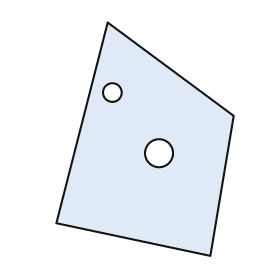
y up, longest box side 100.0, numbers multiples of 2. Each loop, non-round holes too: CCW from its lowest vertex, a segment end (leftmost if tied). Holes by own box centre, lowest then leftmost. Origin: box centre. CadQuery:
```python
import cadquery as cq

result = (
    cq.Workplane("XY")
    .moveTo(28.0, -50.0)
    .lineTo(38.0, 10.0)
    .lineTo(-16.0, 50.0)
    .lineTo(-38.0, -36.0)
    .close()
    .moveTo(6.0, -6.0)
    .circle(6.0)
    .moveTo(-14.0, 20.0)
    .circle(4.0)
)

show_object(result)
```